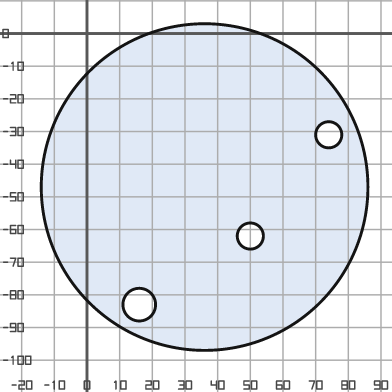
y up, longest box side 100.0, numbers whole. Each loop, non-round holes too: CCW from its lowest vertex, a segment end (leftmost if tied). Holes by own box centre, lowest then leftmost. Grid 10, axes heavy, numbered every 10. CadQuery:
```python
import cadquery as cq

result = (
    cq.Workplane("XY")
    .moveTo(36.0, -47.0)
    .circle(50.0)
    .moveTo(16.0, -83.0)
    .circle(5.0)
    .moveTo(50.0, -62.0)
    .circle(4.0)
    .moveTo(74.0, -31.0)
    .circle(4.0)
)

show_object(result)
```